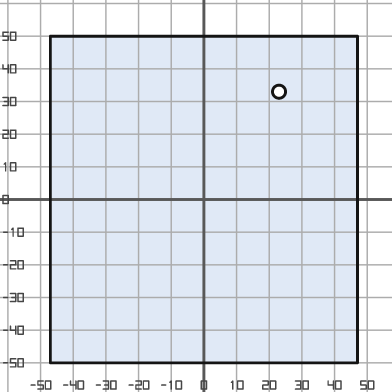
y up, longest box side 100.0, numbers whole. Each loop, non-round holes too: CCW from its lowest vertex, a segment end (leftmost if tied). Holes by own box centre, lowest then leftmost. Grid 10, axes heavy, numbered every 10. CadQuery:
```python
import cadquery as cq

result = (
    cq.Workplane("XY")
    .moveTo(-47.0, -50.0)
    .lineTo(47.0, -50.0)
    .lineTo(47.0, 50.0)
    .lineTo(-47.0, 50.0)
    .close()
    .moveTo(23.0, 33.0)
    .circle(2.0)
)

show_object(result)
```